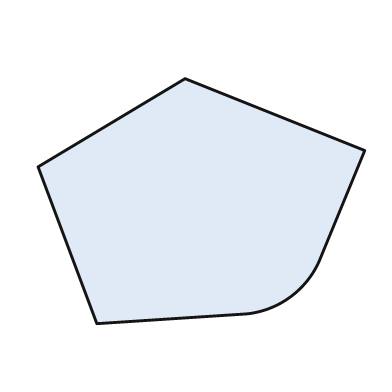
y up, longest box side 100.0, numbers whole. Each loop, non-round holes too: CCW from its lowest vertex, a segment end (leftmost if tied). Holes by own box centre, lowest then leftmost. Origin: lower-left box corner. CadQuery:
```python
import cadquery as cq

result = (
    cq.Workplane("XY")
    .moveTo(18.0, 0.0)
    .lineTo(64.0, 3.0)
    .threePointArc((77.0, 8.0), (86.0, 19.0))
    .lineTo(100.0, 53.0)
    .lineTo(45.0, 75.0)
    .lineTo(0.0, 48.0)
    .close()
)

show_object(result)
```